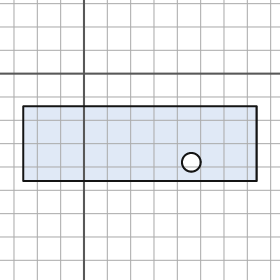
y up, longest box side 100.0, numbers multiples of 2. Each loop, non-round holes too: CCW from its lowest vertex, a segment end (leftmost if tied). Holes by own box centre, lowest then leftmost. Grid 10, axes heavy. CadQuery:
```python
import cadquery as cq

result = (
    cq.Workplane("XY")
    .moveTo(-26.0, -46.0)
    .lineTo(74.0, -46.0)
    .lineTo(74.0, -14.0)
    .lineTo(-26.0, -14.0)
    .close()
    .moveTo(46.0, -38.0)
    .circle(4.0)
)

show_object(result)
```